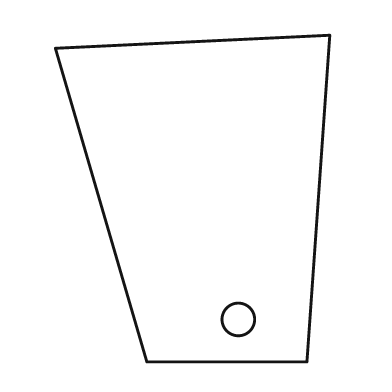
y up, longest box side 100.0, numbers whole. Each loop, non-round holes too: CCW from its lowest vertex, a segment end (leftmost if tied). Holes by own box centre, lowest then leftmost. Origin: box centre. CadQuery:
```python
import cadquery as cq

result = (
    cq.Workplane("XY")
    .moveTo(-14.0, -50.0)
    .lineTo(35.0, -50.0)
    .lineTo(42.0, 50.0)
    .lineTo(-42.0, 46.0)
    .close()
    .moveTo(14.0, -37.0)
    .circle(5.0)
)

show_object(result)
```